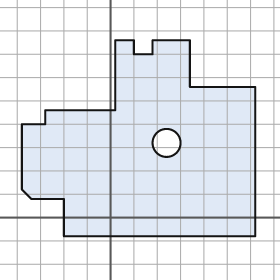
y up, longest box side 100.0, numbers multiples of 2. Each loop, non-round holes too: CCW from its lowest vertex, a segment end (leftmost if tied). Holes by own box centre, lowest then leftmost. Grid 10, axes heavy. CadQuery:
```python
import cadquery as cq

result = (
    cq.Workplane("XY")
    .moveTo(-20.0, -8.0)
    .lineTo(62.0, -8.0)
    .lineTo(62.0, 56.0)
    .lineTo(34.0, 56.0)
    .lineTo(34.0, 76.0)
    .lineTo(18.0, 76.0)
    .lineTo(18.0, 70.0)
    .lineTo(10.0, 70.0)
    .lineTo(10.0, 76.0)
    .lineTo(2.0, 76.0)
    .lineTo(2.0, 46.0)
    .lineTo(-28.0, 46.0)
    .lineTo(-28.0, 40.0)
    .lineTo(-38.0, 40.0)
    .lineTo(-38.0, 12.0)
    .lineTo(-34.0, 8.0)
    .lineTo(-20.0, 8.0)
    .close()
    .moveTo(24.0, 32.0)
    .circle(6.0)
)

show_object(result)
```